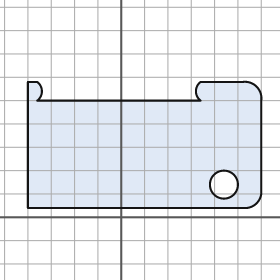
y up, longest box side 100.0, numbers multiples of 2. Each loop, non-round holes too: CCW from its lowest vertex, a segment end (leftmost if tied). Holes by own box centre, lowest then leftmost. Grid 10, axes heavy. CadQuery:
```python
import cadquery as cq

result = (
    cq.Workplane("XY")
    .moveTo(-40.0, 4.0)
    .lineTo(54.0, 4.0)
    .threePointArc((58.0, 6.0), (60.0, 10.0))
    .lineTo(60.0, 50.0)
    .threePointArc((58.0, 56.0), (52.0, 58.0))
    .lineTo(34.0, 58.0)
    .threePointArc((32.0, 54.0), (34.0, 50.0))
    .lineTo(-36.0, 50.0)
    .threePointArc((-34.0, 54.0), (-36.0, 58.0))
    .lineTo(-40.0, 58.0)
    .close()
    .moveTo(44.0, 14.0)
    .circle(6.0)
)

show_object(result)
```